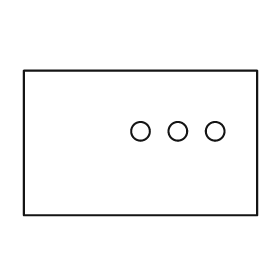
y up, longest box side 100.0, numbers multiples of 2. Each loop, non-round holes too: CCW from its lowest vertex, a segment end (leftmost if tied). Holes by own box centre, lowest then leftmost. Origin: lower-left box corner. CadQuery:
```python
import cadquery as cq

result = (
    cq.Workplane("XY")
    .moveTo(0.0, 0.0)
    .lineTo(100.0, 0.0)
    .lineTo(100.0, 62.0)
    .lineTo(0.0, 62.0)
    .close()
    .moveTo(50.0, 36.0)
    .circle(4.0)
    .moveTo(66.0, 36.0)
    .circle(4.0)
    .moveTo(82.0, 36.0)
    .circle(4.0)
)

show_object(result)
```